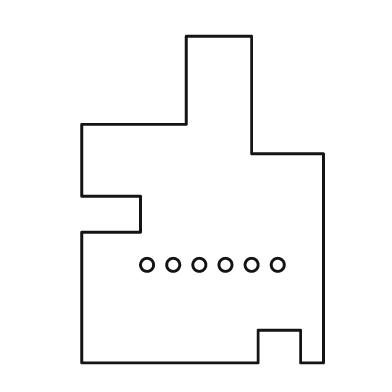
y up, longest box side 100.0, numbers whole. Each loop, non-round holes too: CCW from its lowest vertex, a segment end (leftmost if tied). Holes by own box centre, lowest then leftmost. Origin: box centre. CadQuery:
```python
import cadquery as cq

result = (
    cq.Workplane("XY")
    .moveTo(-37.0, -50.0)
    .lineTo(17.0, -50.0)
    .lineTo(17.0, -40.0)
    .lineTo(30.0, -40.0)
    .lineTo(30.0, -50.0)
    .lineTo(37.0, -50.0)
    .lineTo(37.0, 14.0)
    .lineTo(15.0, 14.0)
    .lineTo(15.0, 50.0)
    .lineTo(-5.0, 50.0)
    .lineTo(-5.0, 23.0)
    .lineTo(-37.0, 23.0)
    .lineTo(-37.0, 1.0)
    .lineTo(-19.0, 1.0)
    .lineTo(-19.0, -10.0)
    .lineTo(-37.0, -10.0)
    .close()
    .moveTo(-17.0, -20.0)
    .circle(2.0)
    .moveTo(-9.0, -20.0)
    .circle(2.0)
    .moveTo(-1.0, -20.0)
    .circle(2.0)
    .moveTo(7.0, -20.0)
    .circle(2.0)
    .moveTo(15.0, -20.0)
    .circle(2.0)
    .moveTo(23.0, -20.0)
    .circle(2.0)
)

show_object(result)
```